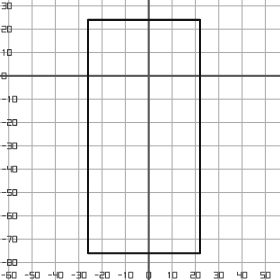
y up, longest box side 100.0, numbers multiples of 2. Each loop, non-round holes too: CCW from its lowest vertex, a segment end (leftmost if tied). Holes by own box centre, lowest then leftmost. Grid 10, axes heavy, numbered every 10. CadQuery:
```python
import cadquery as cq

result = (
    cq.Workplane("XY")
    .moveTo(-26.0, -76.0)
    .lineTo(22.0, -76.0)
    .lineTo(22.0, 24.0)
    .lineTo(-26.0, 24.0)
    .close()
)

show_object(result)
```